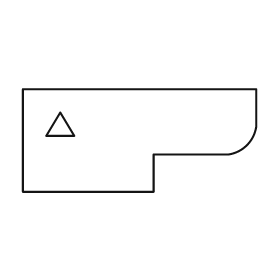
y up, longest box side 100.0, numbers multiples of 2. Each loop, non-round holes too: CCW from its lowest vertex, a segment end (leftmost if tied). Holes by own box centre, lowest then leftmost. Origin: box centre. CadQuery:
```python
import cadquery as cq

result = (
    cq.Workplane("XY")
    .moveTo(-50.0, -22.0)
    .lineTo(6.0, -22.0)
    .lineTo(6.0, -6.0)
    .lineTo(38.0, -6.0)
    .threePointArc((46.0, -2.0), (50.0, 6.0))
    .lineTo(50.0, 22.0)
    .lineTo(-50.0, 22.0)
    .close()
    .moveTo(-40.0, 2.0)
    .lineTo(-28.0, 2.0)
    .lineTo(-34.0, 12.0)
    .close()
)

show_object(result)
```